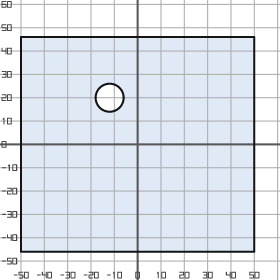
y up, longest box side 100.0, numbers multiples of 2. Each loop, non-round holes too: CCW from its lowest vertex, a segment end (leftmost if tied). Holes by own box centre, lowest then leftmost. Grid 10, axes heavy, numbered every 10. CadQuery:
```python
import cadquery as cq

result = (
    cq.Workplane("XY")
    .moveTo(-50.0, -46.0)
    .lineTo(50.0, -46.0)
    .lineTo(50.0, 46.0)
    .lineTo(-50.0, 46.0)
    .close()
    .moveTo(-12.0, 20.0)
    .circle(6.0)
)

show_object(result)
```